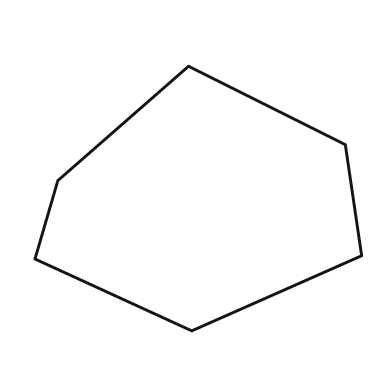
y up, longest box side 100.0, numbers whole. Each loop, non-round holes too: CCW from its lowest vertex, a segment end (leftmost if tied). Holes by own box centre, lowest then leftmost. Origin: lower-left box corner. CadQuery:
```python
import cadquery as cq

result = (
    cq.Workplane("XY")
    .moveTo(48.0, 0.0)
    .lineTo(100.0, 23.0)
    .lineTo(95.0, 57.0)
    .lineTo(47.0, 81.0)
    .lineTo(7.0, 46.0)
    .lineTo(0.0, 22.0)
    .close()
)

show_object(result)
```